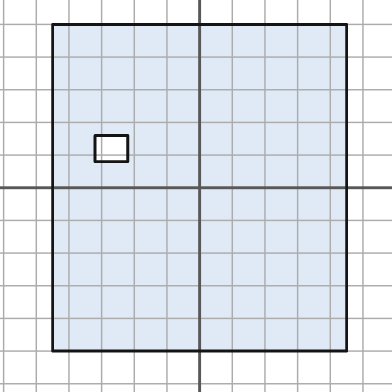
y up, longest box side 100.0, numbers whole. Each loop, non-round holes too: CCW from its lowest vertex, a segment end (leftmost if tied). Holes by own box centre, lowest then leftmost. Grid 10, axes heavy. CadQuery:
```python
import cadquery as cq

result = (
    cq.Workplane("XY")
    .moveTo(-45.0, -50.0)
    .lineTo(45.0, -50.0)
    .lineTo(45.0, 50.0)
    .lineTo(-45.0, 50.0)
    .close()
    .moveTo(-32.0, 8.0)
    .lineTo(-22.0, 8.0)
    .lineTo(-22.0, 16.0)
    .lineTo(-32.0, 16.0)
    .close()
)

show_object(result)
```